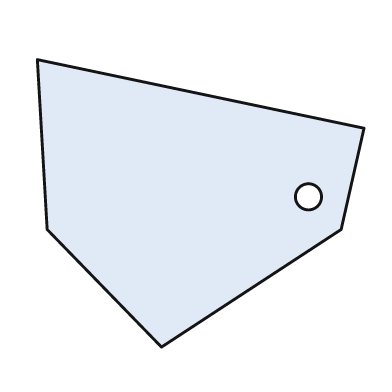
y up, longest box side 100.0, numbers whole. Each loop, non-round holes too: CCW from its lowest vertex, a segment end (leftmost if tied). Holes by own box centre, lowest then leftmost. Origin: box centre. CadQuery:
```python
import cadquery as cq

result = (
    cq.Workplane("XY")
    .moveTo(-12.0, -44.0)
    .lineTo(43.0, -8.0)
    .lineTo(50.0, 23.0)
    .lineTo(-50.0, 44.0)
    .lineTo(-47.0, -8.0)
    .close()
    .moveTo(33.0, 2.0)
    .circle(4.0)
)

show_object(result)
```